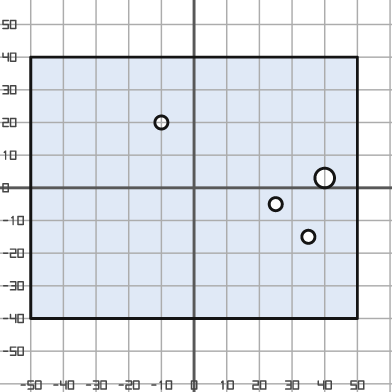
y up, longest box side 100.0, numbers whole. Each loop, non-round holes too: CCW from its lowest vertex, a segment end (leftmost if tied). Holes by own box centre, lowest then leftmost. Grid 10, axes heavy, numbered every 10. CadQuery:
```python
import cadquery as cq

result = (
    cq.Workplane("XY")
    .moveTo(-50.0, -40.0)
    .lineTo(50.0, -40.0)
    .lineTo(50.0, 40.0)
    .lineTo(-50.0, 40.0)
    .close()
    .moveTo(35.0, -15.0)
    .circle(2.0)
    .moveTo(25.0, -5.0)
    .circle(2.0)
    .moveTo(40.0, 3.0)
    .circle(3.0)
    .moveTo(-10.0, 20.0)
    .circle(2.0)
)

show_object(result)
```